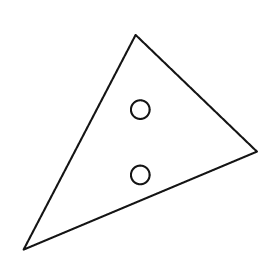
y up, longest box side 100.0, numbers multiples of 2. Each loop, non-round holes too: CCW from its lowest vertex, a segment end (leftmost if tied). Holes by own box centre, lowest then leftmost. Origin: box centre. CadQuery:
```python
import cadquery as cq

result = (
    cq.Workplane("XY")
    .moveTo(-50.0, -46.0)
    .lineTo(50.0, -4.0)
    .lineTo(-2.0, 46.0)
    .close()
    .moveTo(0.0, -14.0)
    .circle(4.0)
    .moveTo(0.0, 14.0)
    .circle(4.0)
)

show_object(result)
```